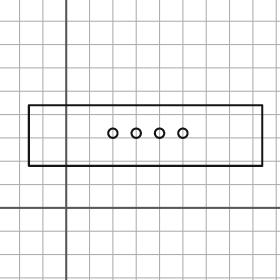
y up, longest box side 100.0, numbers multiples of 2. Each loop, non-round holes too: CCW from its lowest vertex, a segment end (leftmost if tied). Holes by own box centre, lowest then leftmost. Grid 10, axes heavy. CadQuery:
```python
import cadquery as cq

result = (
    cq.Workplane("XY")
    .moveTo(-16.0, 18.0)
    .lineTo(84.0, 18.0)
    .lineTo(84.0, 44.0)
    .lineTo(-16.0, 44.0)
    .close()
    .moveTo(20.0, 32.0)
    .circle(2.0)
    .moveTo(30.0, 32.0)
    .circle(2.0)
    .moveTo(40.0, 32.0)
    .circle(2.0)
    .moveTo(50.0, 32.0)
    .circle(2.0)
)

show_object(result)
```